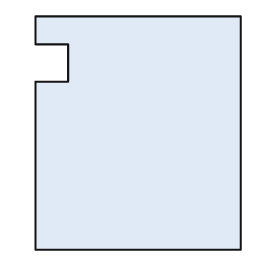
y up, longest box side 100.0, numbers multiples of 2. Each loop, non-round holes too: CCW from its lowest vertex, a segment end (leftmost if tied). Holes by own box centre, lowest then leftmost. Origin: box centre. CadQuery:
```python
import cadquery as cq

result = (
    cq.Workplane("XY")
    .moveTo(-44.0, -50.0)
    .lineTo(44.0, -50.0)
    .lineTo(44.0, 50.0)
    .lineTo(-44.0, 50.0)
    .lineTo(-44.0, 38.0)
    .lineTo(-30.0, 38.0)
    .lineTo(-30.0, 22.0)
    .lineTo(-44.0, 22.0)
    .close()
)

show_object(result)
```